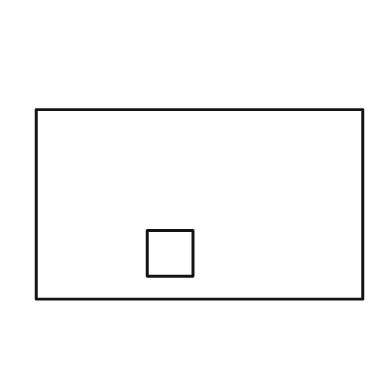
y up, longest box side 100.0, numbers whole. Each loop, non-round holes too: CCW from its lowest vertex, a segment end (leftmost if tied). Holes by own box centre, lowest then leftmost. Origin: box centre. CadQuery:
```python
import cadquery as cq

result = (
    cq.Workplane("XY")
    .moveTo(-50.0, -29.0)
    .lineTo(50.0, -29.0)
    .lineTo(50.0, 29.0)
    .lineTo(-50.0, 29.0)
    .close()
    .moveTo(-16.0, -22.0)
    .lineTo(-2.0, -22.0)
    .lineTo(-2.0, -8.0)
    .lineTo(-16.0, -8.0)
    .close()
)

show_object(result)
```